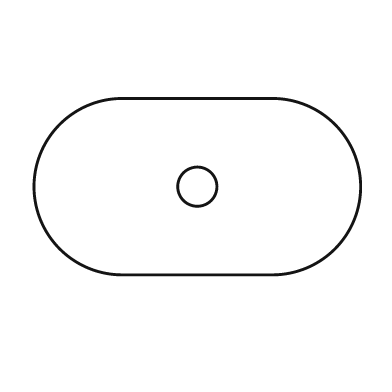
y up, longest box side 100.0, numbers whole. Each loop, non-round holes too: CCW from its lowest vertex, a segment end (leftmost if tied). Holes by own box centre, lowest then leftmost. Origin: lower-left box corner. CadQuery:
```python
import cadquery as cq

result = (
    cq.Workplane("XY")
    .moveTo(27.0, 0.0)
    .lineTo(73.0, 0.0)
    .threePointArc((100.0, 27.0), (73.0, 54.0))
    .lineTo(27.0, 54.0)
    .threePointArc((0.0, 27.0), (27.0, 0.0))
    .close()
    .moveTo(50.0, 27.0)
    .circle(6.0)
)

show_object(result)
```